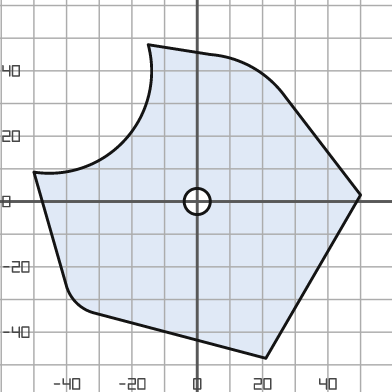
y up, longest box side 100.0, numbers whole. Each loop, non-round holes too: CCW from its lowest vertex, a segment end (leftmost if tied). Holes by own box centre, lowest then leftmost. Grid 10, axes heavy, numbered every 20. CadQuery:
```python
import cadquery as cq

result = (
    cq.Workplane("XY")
    .moveTo(21.0, -48.0)
    .lineTo(50.0, 2.0)
    .lineTo(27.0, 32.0)
    .threePointArc((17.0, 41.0), (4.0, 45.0))
    .lineTo(-15.0, 48.0)
    .threePointArc((-22.0, 19.0), (-50.0, 9.0))
    .lineTo(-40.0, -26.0)
    .threePointArc((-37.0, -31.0), (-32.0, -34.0))
    .close()
    .moveTo(0.0, 0.0)
    .circle(4.0)
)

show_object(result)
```